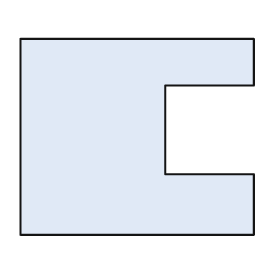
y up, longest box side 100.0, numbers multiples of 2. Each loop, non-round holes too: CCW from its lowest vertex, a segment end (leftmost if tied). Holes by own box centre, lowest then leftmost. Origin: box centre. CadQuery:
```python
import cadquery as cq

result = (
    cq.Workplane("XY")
    .moveTo(-50.0, -42.0)
    .lineTo(50.0, -42.0)
    .lineTo(50.0, -16.0)
    .lineTo(12.0, -16.0)
    .lineTo(12.0, 22.0)
    .lineTo(50.0, 22.0)
    .lineTo(50.0, 42.0)
    .lineTo(-50.0, 42.0)
    .close()
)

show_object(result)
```